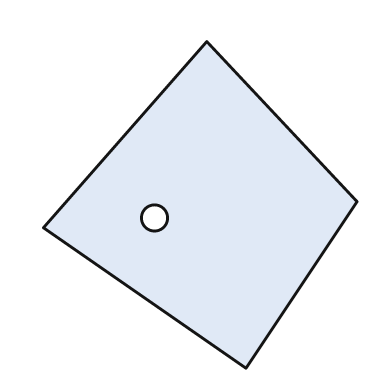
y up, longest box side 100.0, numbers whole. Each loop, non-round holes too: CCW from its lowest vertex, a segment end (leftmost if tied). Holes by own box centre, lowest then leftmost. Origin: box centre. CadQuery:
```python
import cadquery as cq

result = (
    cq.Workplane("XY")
    .moveTo(14.0, -50.0)
    .lineTo(48.0, 1.0)
    .lineTo(2.0, 50.0)
    .lineTo(-48.0, -7.0)
    .close()
    .moveTo(-14.0, -4.0)
    .circle(4.0)
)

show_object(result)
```